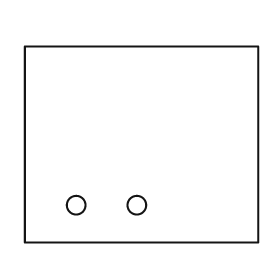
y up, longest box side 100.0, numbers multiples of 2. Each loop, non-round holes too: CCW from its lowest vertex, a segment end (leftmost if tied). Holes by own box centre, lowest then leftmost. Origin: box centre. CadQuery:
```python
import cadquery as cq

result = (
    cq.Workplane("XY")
    .moveTo(-50.0, -42.0)
    .lineTo(50.0, -42.0)
    .lineTo(50.0, 42.0)
    .lineTo(-50.0, 42.0)
    .close()
    .moveTo(-28.0, -26.0)
    .circle(4.0)
    .moveTo(-2.0, -26.0)
    .circle(4.0)
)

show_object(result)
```